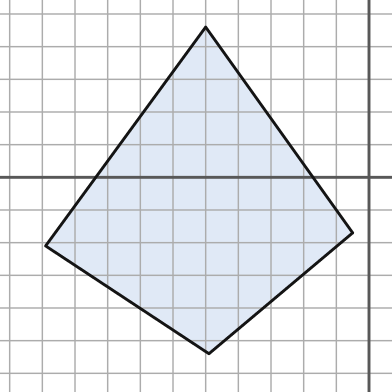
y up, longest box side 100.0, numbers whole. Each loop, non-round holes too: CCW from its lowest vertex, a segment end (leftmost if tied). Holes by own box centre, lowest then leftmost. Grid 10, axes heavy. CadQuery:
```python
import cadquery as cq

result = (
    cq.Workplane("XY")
    .moveTo(-49.0, -54.0)
    .lineTo(-5.0, -17.0)
    .lineTo(-50.0, 46.0)
    .lineTo(-99.0, -21.0)
    .close()
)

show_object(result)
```